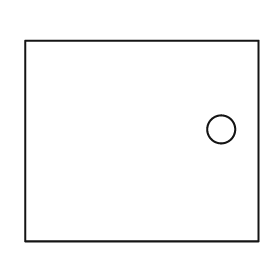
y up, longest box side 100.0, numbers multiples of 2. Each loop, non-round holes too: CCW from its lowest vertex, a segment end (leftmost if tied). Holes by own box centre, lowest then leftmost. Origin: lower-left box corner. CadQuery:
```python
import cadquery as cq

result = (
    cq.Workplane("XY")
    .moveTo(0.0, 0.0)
    .lineTo(100.0, 0.0)
    .lineTo(100.0, 86.0)
    .lineTo(0.0, 86.0)
    .close()
    .moveTo(84.0, 48.0)
    .circle(6.0)
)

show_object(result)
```